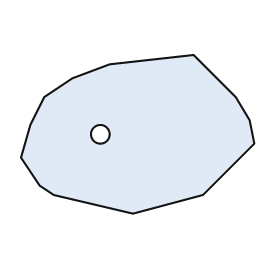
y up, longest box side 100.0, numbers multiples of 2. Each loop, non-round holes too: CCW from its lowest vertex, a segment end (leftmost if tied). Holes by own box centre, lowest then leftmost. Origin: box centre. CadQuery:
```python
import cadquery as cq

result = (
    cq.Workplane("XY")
    .moveTo(-2.0, -34.0)
    .lineTo(28.0, -26.0)
    .lineTo(50.0, -4.0)
    .lineTo(48.0, 6.0)
    .lineTo(42.0, 16.0)
    .lineTo(24.0, 34.0)
    .lineTo(-12.0, 30.0)
    .lineTo(-28.0, 24.0)
    .lineTo(-40.0, 16.0)
    .lineTo(-46.0, 4.0)
    .lineTo(-50.0, -10.0)
    .lineTo(-42.0, -22.0)
    .lineTo(-36.0, -26.0)
    .close()
    .moveTo(-16.0, 0.0)
    .circle(4.0)
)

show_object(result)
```